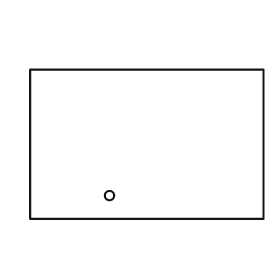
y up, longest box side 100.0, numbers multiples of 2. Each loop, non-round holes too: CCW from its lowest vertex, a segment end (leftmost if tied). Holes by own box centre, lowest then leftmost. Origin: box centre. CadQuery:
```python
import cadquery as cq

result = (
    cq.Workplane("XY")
    .moveTo(-50.0, -32.0)
    .lineTo(50.0, -32.0)
    .lineTo(50.0, 32.0)
    .lineTo(-50.0, 32.0)
    .close()
    .moveTo(-16.0, -22.0)
    .circle(2.0)
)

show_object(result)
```